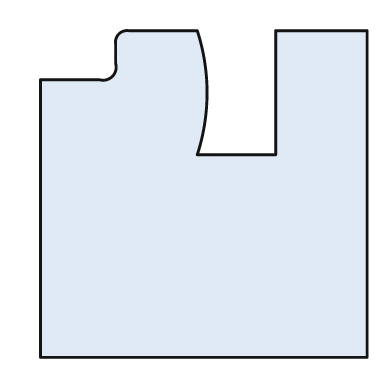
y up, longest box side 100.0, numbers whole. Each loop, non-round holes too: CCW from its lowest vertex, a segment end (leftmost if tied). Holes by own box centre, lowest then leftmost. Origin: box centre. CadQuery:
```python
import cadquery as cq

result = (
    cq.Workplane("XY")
    .moveTo(-50.0, -50.0)
    .lineTo(50.0, -50.0)
    .lineTo(50.0, 50.0)
    .lineTo(22.0, 50.0)
    .lineTo(22.0, 12.0)
    .lineTo(-2.0, 12.0)
    .threePointArc((1.0, 31.0), (-2.0, 50.0))
    .lineTo(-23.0, 50.0)
    .threePointArc((-26.0, 49.0), (-27.0, 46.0))
    .lineTo(-27.0, 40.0)
    .threePointArc((-28.0, 36.0), (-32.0, 35.0))
    .lineTo(-50.0, 35.0)
    .close()
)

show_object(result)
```